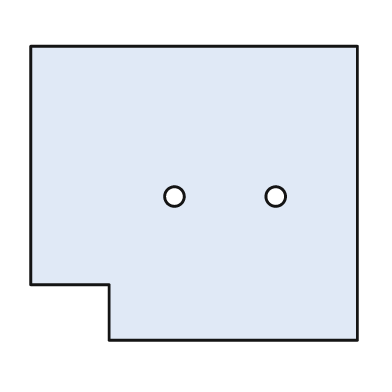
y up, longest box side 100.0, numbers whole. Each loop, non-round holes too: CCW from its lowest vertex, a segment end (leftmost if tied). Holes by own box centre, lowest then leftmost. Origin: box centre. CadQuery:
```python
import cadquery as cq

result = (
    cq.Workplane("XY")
    .moveTo(-26.0, -45.0)
    .lineTo(50.0, -45.0)
    .lineTo(50.0, 45.0)
    .lineTo(-50.0, 45.0)
    .lineTo(-50.0, -28.0)
    .lineTo(-26.0, -28.0)
    .close()
    .moveTo(-6.0, -1.0)
    .circle(3.0)
    .moveTo(25.0, -1.0)
    .circle(3.0)
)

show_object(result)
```